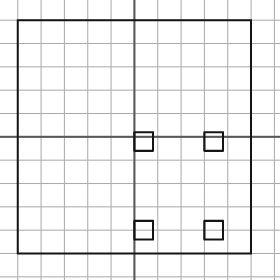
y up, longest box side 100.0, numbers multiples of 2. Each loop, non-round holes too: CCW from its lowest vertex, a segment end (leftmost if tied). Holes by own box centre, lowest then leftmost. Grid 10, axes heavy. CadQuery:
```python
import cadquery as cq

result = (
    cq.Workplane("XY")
    .moveTo(-50.0, -50.0)
    .lineTo(50.0, -50.0)
    .lineTo(50.0, 50.0)
    .lineTo(-50.0, 50.0)
    .close()
    .moveTo(0.0, -44.0)
    .lineTo(8.0, -44.0)
    .lineTo(8.0, -36.0)
    .lineTo(0.0, -36.0)
    .close()
    .moveTo(30.0, -44.0)
    .lineTo(38.0, -44.0)
    .lineTo(38.0, -36.0)
    .lineTo(30.0, -36.0)
    .close()
    .moveTo(0.0, -6.0)
    .lineTo(8.0, -6.0)
    .lineTo(8.0, 2.0)
    .lineTo(0.0, 2.0)
    .close()
    .moveTo(30.0, -6.0)
    .lineTo(38.0, -6.0)
    .lineTo(38.0, 2.0)
    .lineTo(30.0, 2.0)
    .close()
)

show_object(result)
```